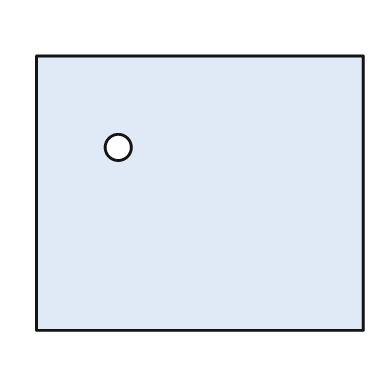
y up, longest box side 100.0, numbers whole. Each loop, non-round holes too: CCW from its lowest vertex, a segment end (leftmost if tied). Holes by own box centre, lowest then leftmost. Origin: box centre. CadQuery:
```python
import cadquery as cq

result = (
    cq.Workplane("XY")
    .moveTo(-50.0, -42.0)
    .lineTo(50.0, -42.0)
    .lineTo(50.0, 42.0)
    .lineTo(-50.0, 42.0)
    .close()
    .moveTo(-25.0, 14.0)
    .circle(4.0)
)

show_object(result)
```